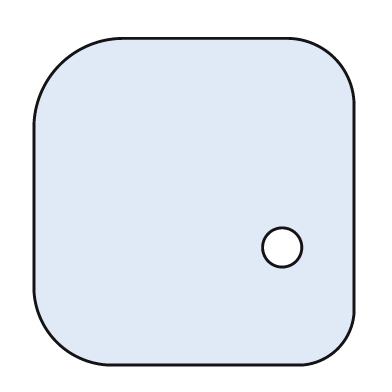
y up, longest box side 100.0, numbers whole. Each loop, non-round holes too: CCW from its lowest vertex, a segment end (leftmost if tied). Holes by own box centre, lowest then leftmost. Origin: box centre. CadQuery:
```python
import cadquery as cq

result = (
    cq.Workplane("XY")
    .moveTo(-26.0, -50.0)
    .lineTo(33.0, -50.0)
    .threePointArc((44.0, -45.0), (49.0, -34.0))
    .lineTo(49.0, 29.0)
    .threePointArc((43.0, 44.0), (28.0, 50.0))
    .lineTo(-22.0, 50.0)
    .threePointArc((-41.0, 42.0), (-49.0, 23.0))
    .lineTo(-49.0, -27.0)
    .threePointArc((-42.0, -43.0), (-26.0, -50.0))
    .close()
    .moveTo(27.0, -14.0)
    .circle(6.0)
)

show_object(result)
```